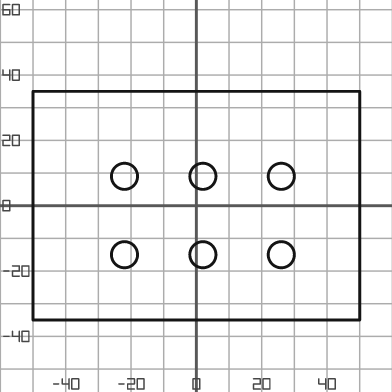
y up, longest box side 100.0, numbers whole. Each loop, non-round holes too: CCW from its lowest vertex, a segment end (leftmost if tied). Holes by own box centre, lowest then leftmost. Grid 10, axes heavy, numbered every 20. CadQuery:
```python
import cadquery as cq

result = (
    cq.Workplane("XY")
    .moveTo(-50.0, -35.0)
    .lineTo(50.0, -35.0)
    .lineTo(50.0, 35.0)
    .lineTo(-50.0, 35.0)
    .close()
    .moveTo(-22.0, -15.0)
    .circle(4.0)
    .moveTo(2.0, -15.0)
    .circle(4.0)
    .moveTo(26.0, -15.0)
    .circle(4.0)
    .moveTo(-22.0, 9.0)
    .circle(4.0)
    .moveTo(2.0, 9.0)
    .circle(4.0)
    .moveTo(26.0, 9.0)
    .circle(4.0)
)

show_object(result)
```